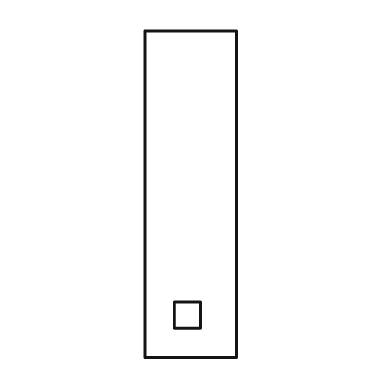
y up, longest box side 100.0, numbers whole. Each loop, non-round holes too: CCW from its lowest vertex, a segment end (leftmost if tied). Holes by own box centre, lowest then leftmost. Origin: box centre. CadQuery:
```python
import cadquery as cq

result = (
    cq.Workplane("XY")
    .moveTo(-14.0, -50.0)
    .lineTo(14.0, -50.0)
    .lineTo(14.0, 50.0)
    .lineTo(-14.0, 50.0)
    .close()
    .moveTo(-5.0, -41.0)
    .lineTo(3.0, -41.0)
    .lineTo(3.0, -33.0)
    .lineTo(-5.0, -33.0)
    .close()
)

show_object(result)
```